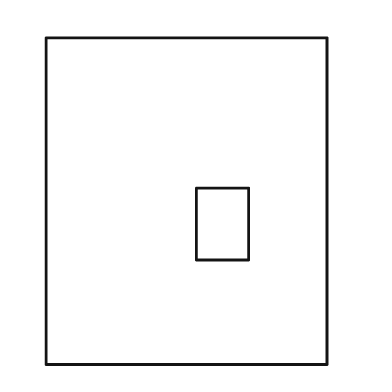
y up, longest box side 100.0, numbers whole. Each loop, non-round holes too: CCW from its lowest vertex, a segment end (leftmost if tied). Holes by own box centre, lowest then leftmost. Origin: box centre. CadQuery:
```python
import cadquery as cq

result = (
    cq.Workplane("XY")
    .moveTo(-43.0, -50.0)
    .lineTo(43.0, -50.0)
    .lineTo(43.0, 50.0)
    .lineTo(-43.0, 50.0)
    .close()
    .moveTo(3.0, -18.0)
    .lineTo(19.0, -18.0)
    .lineTo(19.0, 4.0)
    .lineTo(3.0, 4.0)
    .close()
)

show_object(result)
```